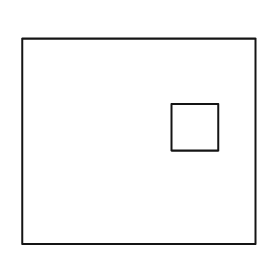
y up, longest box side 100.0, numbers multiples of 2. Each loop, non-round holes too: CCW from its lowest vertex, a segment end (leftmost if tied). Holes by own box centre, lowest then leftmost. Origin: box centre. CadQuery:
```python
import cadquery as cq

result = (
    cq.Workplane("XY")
    .moveTo(-50.0, -44.0)
    .lineTo(50.0, -44.0)
    .lineTo(50.0, 44.0)
    .lineTo(-50.0, 44.0)
    .close()
    .moveTo(14.0, -4.0)
    .lineTo(34.0, -4.0)
    .lineTo(34.0, 16.0)
    .lineTo(14.0, 16.0)
    .close()
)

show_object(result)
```